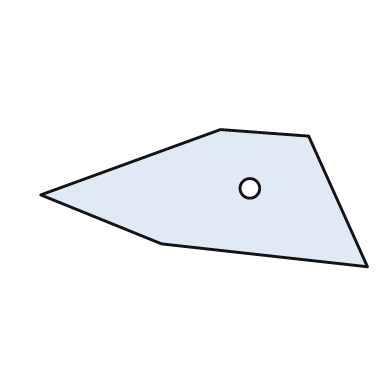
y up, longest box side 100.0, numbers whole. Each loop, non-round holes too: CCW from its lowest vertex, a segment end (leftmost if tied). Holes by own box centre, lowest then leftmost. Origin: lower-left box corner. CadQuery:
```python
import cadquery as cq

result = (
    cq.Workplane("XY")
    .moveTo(100.0, 0.0)
    .lineTo(82.0, 40.0)
    .lineTo(55.0, 42.0)
    .lineTo(0.0, 22.0)
    .lineTo(37.0, 7.0)
    .close()
    .moveTo(64.0, 24.0)
    .circle(3.0)
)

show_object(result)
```